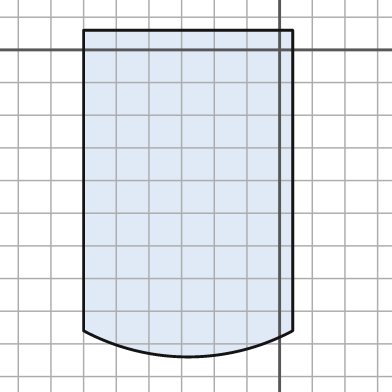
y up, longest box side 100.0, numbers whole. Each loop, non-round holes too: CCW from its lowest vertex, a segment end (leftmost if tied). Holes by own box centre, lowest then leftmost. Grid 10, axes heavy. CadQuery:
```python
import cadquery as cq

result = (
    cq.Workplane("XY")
    .moveTo(-60.0, -86.0)
    .threePointArc((-28.0, -94.0), (4.0, -86.0))
    .lineTo(4.0, 6.0)
    .lineTo(-60.0, 6.0)
    .close()
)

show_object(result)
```